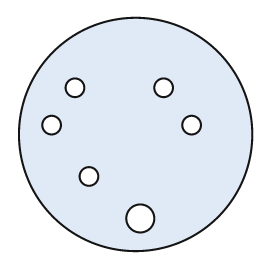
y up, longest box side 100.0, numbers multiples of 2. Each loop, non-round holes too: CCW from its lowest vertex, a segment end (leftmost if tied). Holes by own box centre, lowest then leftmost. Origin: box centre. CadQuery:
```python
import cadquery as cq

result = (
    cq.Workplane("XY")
    .moveTo(0.0, 0.0)
    .circle(50.0)
    .moveTo(2.0, -36.0)
    .circle(6.0)
    .moveTo(-20.0, -18.0)
    .circle(4.0)
    .moveTo(-36.0, 4.0)
    .circle(4.0)
    .moveTo(24.0, 4.0)
    .circle(4.0)
    .moveTo(-26.0, 20.0)
    .circle(4.0)
    .moveTo(12.0, 20.0)
    .circle(4.0)
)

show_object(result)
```